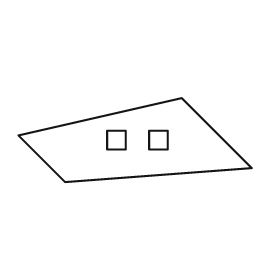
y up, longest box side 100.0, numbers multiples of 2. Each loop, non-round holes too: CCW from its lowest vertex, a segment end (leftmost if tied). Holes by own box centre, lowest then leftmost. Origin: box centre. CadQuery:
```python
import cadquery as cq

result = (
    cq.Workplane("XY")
    .moveTo(-30.0, -18.0)
    .lineTo(50.0, -12.0)
    .lineTo(20.0, 18.0)
    .lineTo(-50.0, 2.0)
    .close()
    .moveTo(-12.0, -4.0)
    .lineTo(-4.0, -4.0)
    .lineTo(-4.0, 4.0)
    .lineTo(-12.0, 4.0)
    .close()
    .moveTo(6.0, -4.0)
    .lineTo(14.0, -4.0)
    .lineTo(14.0, 4.0)
    .lineTo(6.0, 4.0)
    .close()
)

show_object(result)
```